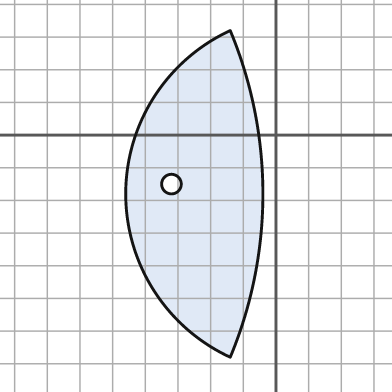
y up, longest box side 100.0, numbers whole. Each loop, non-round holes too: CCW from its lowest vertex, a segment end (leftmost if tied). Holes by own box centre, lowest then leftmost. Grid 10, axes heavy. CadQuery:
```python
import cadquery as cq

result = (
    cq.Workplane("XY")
    .moveTo(-14.0, -68.0)
    .threePointArc((-4.0, -18.0), (-14.0, 32.0))
    .threePointArc((-46.0, -18.0), (-14.0, -68.0))
    .close()
    .moveTo(-32.0, -15.0)
    .circle(3.0)
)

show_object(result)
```